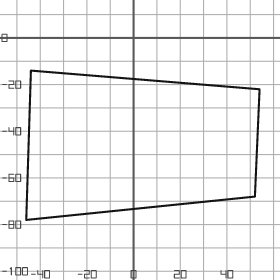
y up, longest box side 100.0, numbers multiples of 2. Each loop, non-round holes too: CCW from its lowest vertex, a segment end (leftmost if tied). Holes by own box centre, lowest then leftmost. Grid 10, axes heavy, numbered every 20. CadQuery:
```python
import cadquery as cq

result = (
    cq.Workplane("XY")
    .moveTo(-46.0, -78.0)
    .lineTo(52.0, -68.0)
    .lineTo(54.0, -22.0)
    .lineTo(-44.0, -14.0)
    .close()
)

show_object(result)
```